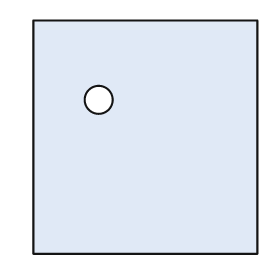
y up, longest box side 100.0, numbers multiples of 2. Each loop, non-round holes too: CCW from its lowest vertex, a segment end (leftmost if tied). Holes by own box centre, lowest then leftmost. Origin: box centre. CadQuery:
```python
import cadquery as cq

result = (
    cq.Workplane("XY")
    .moveTo(-48.0, -50.0)
    .lineTo(48.0, -50.0)
    .lineTo(48.0, 50.0)
    .lineTo(-48.0, 50.0)
    .close()
    .moveTo(-20.0, 16.0)
    .circle(6.0)
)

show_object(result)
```